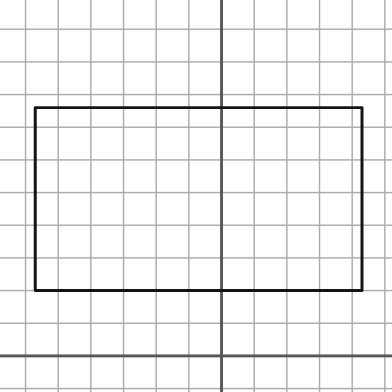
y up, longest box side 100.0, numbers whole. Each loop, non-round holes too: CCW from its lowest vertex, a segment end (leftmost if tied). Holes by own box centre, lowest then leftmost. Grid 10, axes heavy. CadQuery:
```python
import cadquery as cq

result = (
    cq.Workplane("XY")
    .moveTo(-57.0, 20.0)
    .lineTo(43.0, 20.0)
    .lineTo(43.0, 76.0)
    .lineTo(-57.0, 76.0)
    .close()
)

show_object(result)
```